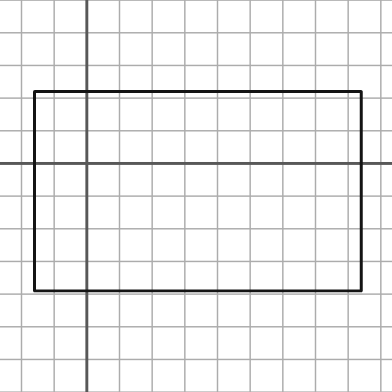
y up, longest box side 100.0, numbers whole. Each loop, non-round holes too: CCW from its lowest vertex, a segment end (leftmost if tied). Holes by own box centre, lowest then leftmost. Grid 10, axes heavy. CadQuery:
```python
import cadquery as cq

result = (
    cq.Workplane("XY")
    .moveTo(-16.0, -39.0)
    .lineTo(84.0, -39.0)
    .lineTo(84.0, 22.0)
    .lineTo(-16.0, 22.0)
    .close()
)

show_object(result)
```